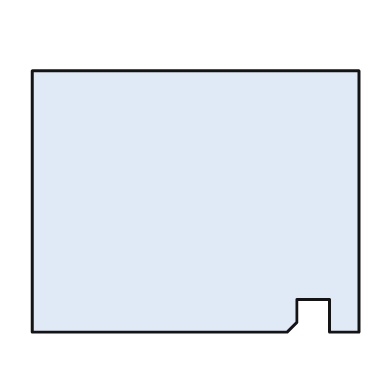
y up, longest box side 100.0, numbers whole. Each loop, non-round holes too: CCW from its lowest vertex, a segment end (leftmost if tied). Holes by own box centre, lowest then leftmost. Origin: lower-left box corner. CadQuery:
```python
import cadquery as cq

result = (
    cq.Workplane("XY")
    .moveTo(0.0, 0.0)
    .lineTo(78.0, 0.0)
    .lineTo(81.0, 3.0)
    .lineTo(81.0, 10.0)
    .lineTo(91.0, 10.0)
    .lineTo(91.0, 0.0)
    .lineTo(100.0, 0.0)
    .lineTo(100.0, 80.0)
    .lineTo(0.0, 80.0)
    .close()
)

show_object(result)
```